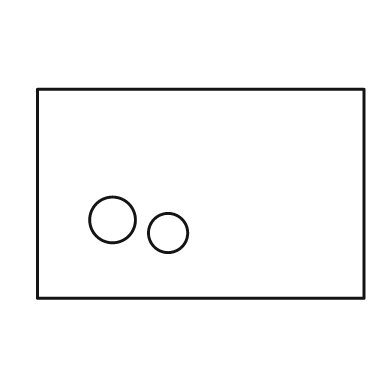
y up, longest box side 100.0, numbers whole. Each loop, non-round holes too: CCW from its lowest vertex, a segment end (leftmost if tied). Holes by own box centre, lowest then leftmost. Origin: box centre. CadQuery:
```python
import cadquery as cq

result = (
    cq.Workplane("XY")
    .moveTo(-50.0, -32.0)
    .lineTo(50.0, -32.0)
    .lineTo(50.0, 32.0)
    .lineTo(-50.0, 32.0)
    .close()
    .moveTo(-10.0, -12.0)
    .circle(6.0)
    .moveTo(-27.0, -8.0)
    .circle(7.0)
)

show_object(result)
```